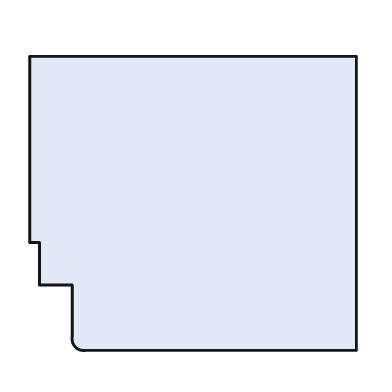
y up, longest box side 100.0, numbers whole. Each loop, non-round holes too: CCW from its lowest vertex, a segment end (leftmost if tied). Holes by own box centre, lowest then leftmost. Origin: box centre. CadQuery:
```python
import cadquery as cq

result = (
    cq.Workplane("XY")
    .moveTo(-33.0, -45.0)
    .lineTo(50.0, -45.0)
    .lineTo(50.0, 45.0)
    .lineTo(-50.0, 45.0)
    .lineTo(-50.0, -12.0)
    .lineTo(-47.0, -12.0)
    .lineTo(-47.0, -25.0)
    .lineTo(-37.0, -25.0)
    .lineTo(-37.0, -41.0)
    .threePointArc((-36.0, -44.0), (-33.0, -45.0))
    .close()
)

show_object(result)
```